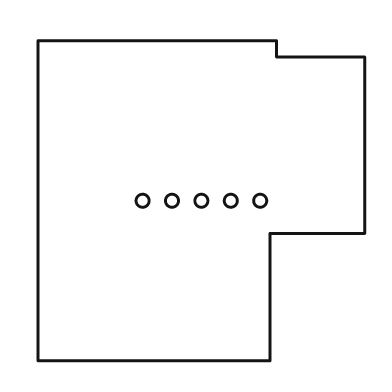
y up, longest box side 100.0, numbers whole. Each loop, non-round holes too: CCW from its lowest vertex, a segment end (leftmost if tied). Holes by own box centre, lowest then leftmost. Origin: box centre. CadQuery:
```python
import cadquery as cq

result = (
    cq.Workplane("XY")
    .moveTo(-50.0, -49.0)
    .lineTo(21.0, -49.0)
    .lineTo(21.0, -10.0)
    .lineTo(50.0, -10.0)
    .lineTo(50.0, 44.0)
    .lineTo(23.0, 44.0)
    .lineTo(23.0, 49.0)
    .lineTo(-50.0, 49.0)
    .close()
    .moveTo(-18.0, 0.0)
    .circle(2.0)
    .moveTo(-9.0, 0.0)
    .circle(2.0)
    .moveTo(0.0, 0.0)
    .circle(2.0)
    .moveTo(9.0, 0.0)
    .circle(2.0)
    .moveTo(18.0, 0.0)
    .circle(2.0)
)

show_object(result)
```